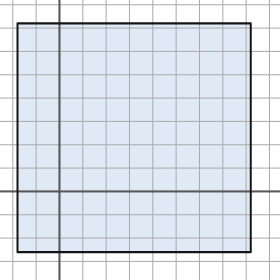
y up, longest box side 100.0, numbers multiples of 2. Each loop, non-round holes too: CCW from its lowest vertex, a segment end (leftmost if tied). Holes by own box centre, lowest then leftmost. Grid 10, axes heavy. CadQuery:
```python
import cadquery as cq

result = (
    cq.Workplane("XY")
    .moveTo(-18.0, -26.0)
    .lineTo(82.0, -26.0)
    .lineTo(82.0, 72.0)
    .lineTo(-18.0, 72.0)
    .close()
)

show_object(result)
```